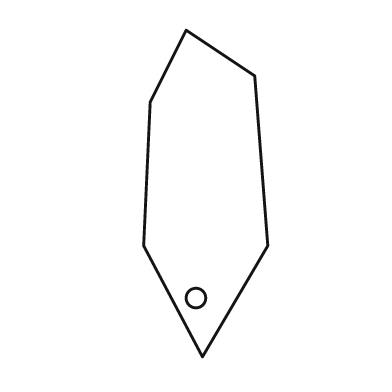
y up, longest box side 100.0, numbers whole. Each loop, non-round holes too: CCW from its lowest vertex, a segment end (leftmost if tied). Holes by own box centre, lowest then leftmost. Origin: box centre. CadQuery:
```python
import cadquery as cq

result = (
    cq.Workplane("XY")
    .moveTo(-1.0, -50.0)
    .lineTo(19.0, -16.0)
    .lineTo(15.0, 36.0)
    .lineTo(-6.0, 50.0)
    .lineTo(-17.0, 28.0)
    .lineTo(-19.0, -16.0)
    .close()
    .moveTo(-3.0, -32.0)
    .circle(3.0)
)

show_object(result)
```